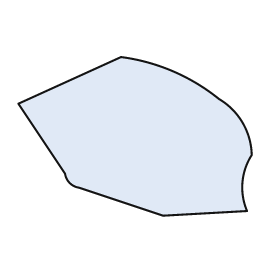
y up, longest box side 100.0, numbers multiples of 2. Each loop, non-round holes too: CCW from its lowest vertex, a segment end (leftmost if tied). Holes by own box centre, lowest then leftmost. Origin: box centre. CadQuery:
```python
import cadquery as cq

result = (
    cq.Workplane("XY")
    .moveTo(12.0, -34.0)
    .lineTo(48.0, -32.0)
    .threePointArc((46.0, -20.0), (50.0, -8.0))
    .threePointArc((46.0, 6.0), (36.0, 16.0))
    .threePointArc((16.0, 28.0), (-6.0, 34.0))
    .lineTo(-50.0, 14.0)
    .lineTo(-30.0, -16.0)
    .threePointArc((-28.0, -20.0), (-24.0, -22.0))
    .close()
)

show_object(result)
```